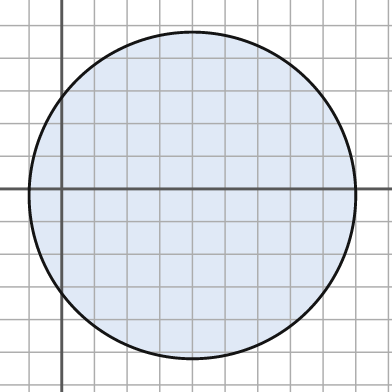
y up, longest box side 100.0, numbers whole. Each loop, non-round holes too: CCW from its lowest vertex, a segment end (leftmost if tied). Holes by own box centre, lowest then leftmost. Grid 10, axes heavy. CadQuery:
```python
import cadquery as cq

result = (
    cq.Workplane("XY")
    .moveTo(40.0, -2.0)
    .circle(50.0)
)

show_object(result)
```